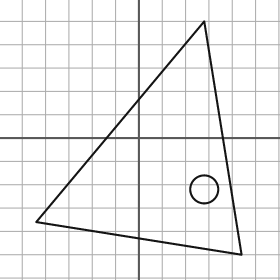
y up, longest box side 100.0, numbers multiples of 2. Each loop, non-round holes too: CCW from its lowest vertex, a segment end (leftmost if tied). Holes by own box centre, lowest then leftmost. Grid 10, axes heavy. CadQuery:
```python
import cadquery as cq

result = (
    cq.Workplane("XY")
    .moveTo(44.0, -50.0)
    .lineTo(28.0, 50.0)
    .lineTo(-44.0, -36.0)
    .close()
    .moveTo(28.0, -22.0)
    .circle(6.0)
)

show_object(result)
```